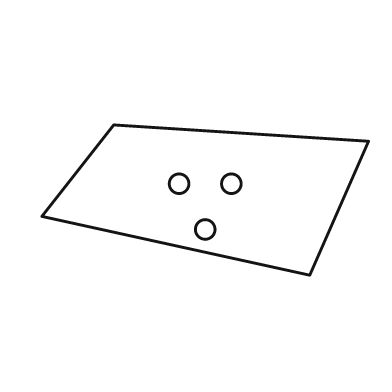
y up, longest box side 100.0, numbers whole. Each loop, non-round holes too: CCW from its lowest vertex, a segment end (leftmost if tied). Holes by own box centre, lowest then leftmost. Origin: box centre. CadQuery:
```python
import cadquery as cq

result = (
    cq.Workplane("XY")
    .moveTo(32.0, -23.0)
    .lineTo(50.0, 18.0)
    .lineTo(-28.0, 23.0)
    .lineTo(-50.0, -5.0)
    .close()
    .moveTo(0.0, -9.0)
    .circle(3.0)
    .moveTo(-8.0, 5.0)
    .circle(3.0)
    .moveTo(8.0, 5.0)
    .circle(3.0)
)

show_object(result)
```